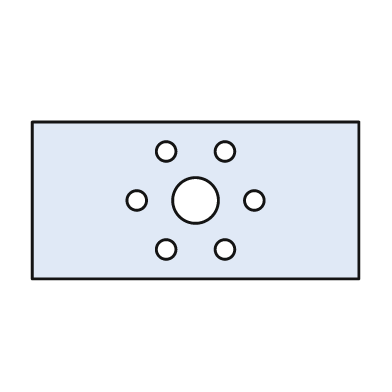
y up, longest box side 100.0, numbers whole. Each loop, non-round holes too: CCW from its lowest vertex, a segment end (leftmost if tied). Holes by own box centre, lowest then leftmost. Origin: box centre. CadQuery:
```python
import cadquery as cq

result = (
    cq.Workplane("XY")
    .moveTo(-50.0, -24.0)
    .lineTo(50.0, -24.0)
    .lineTo(50.0, 24.0)
    .lineTo(-50.0, 24.0)
    .close()
    .moveTo(-9.0, -15.0)
    .circle(3.0)
    .moveTo(9.0, -15.0)
    .circle(3.0)
    .moveTo(-18.0, 0.0)
    .circle(3.0)
    .moveTo(0.0, 0.0)
    .circle(7.0)
    .moveTo(18.0, 0.0)
    .circle(3.0)
    .moveTo(-9.0, 15.0)
    .circle(3.0)
    .moveTo(9.0, 15.0)
    .circle(3.0)
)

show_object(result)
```